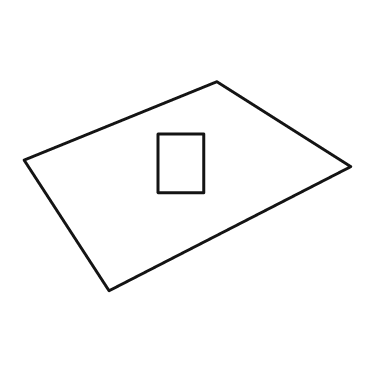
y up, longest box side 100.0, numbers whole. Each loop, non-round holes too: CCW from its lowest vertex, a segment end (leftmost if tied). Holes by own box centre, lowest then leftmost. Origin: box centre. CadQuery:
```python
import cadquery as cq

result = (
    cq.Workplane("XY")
    .moveTo(-24.0, -32.0)
    .lineTo(50.0, 6.0)
    .lineTo(9.0, 32.0)
    .lineTo(-50.0, 8.0)
    .close()
    .moveTo(-9.0, -2.0)
    .lineTo(5.0, -2.0)
    .lineTo(5.0, 16.0)
    .lineTo(-9.0, 16.0)
    .close()
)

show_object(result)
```